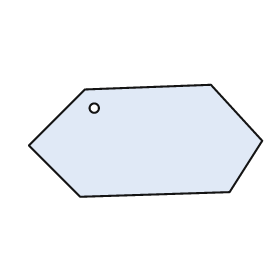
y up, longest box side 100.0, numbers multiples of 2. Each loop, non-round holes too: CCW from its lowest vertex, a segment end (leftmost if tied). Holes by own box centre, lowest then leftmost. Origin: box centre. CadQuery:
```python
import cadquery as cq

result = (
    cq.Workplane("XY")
    .moveTo(-28.0, -24.0)
    .lineTo(36.0, -22.0)
    .lineTo(50.0, 0.0)
    .lineTo(28.0, 24.0)
    .lineTo(-26.0, 22.0)
    .lineTo(-50.0, -2.0)
    .close()
    .moveTo(-22.0, 14.0)
    .circle(2.0)
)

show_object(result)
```